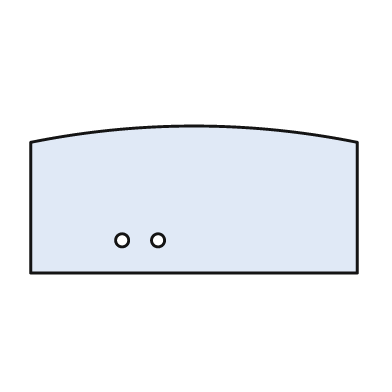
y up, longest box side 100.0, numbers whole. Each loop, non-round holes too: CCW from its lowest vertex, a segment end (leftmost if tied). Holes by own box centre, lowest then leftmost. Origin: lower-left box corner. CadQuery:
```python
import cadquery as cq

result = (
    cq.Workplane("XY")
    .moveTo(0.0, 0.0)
    .lineTo(100.0, 0.0)
    .lineTo(100.0, 40.0)
    .threePointArc((50.0, 45.0), (0.0, 40.0))
    .close()
    .moveTo(28.0, 10.0)
    .circle(2.0)
    .moveTo(39.0, 10.0)
    .circle(2.0)
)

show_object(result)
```